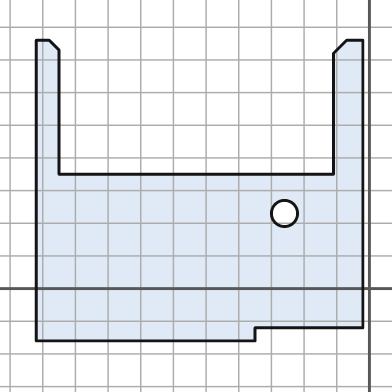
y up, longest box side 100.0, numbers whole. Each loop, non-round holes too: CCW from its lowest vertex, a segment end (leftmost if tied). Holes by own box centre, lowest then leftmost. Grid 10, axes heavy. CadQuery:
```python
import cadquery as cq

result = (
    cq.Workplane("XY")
    .moveTo(-102.0, -16.0)
    .lineTo(-35.0, -16.0)
    .lineTo(-35.0, -12.0)
    .lineTo(-2.0, -12.0)
    .lineTo(-2.0, 76.0)
    .lineTo(-7.0, 76.0)
    .lineTo(-11.0, 72.0)
    .lineTo(-11.0, 35.0)
    .lineTo(-95.0, 35.0)
    .lineTo(-95.0, 73.0)
    .lineTo(-98.0, 76.0)
    .lineTo(-102.0, 76.0)
    .close()
    .moveTo(-26.0, 23.0)
    .circle(4.0)
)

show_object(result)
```